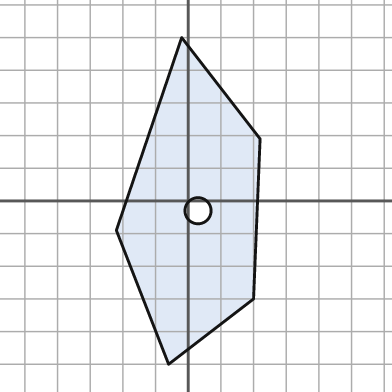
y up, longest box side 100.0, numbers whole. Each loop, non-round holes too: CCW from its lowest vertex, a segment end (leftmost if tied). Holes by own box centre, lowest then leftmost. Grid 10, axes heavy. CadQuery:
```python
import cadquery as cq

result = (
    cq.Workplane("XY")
    .moveTo(-6.0, -50.0)
    .lineTo(20.0, -30.0)
    .lineTo(22.0, 19.0)
    .lineTo(-2.0, 50.0)
    .lineTo(-22.0, -9.0)
    .close()
    .moveTo(3.0, -3.0)
    .circle(4.0)
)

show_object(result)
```